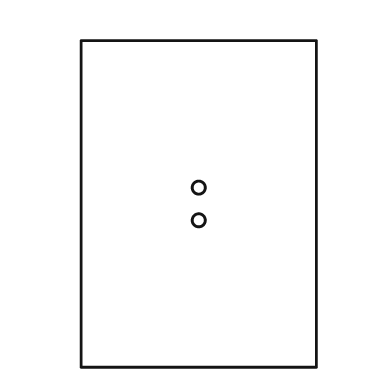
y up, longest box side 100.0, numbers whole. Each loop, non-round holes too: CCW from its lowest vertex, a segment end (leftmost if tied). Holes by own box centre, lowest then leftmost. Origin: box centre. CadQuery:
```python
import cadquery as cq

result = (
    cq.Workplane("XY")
    .moveTo(-36.0, -50.0)
    .lineTo(36.0, -50.0)
    .lineTo(36.0, 50.0)
    .lineTo(-36.0, 50.0)
    .close()
    .moveTo(0.0, -5.0)
    .circle(2.0)
    .moveTo(0.0, 5.0)
    .circle(2.0)
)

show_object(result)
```